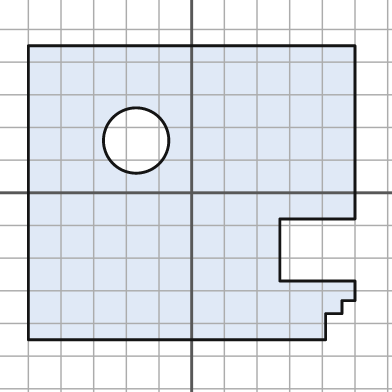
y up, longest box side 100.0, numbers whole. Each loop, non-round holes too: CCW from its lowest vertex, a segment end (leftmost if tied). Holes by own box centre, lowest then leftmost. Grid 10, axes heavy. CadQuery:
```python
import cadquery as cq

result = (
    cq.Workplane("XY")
    .moveTo(-50.0, -45.0)
    .lineTo(41.0, -45.0)
    .lineTo(41.0, -37.0)
    .lineTo(46.0, -37.0)
    .lineTo(46.0, -33.0)
    .lineTo(50.0, -33.0)
    .lineTo(50.0, -27.0)
    .lineTo(27.0, -27.0)
    .lineTo(27.0, -8.0)
    .lineTo(50.0, -8.0)
    .lineTo(50.0, 45.0)
    .lineTo(-50.0, 45.0)
    .close()
    .moveTo(-17.0, 16.0)
    .circle(10.0)
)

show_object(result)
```